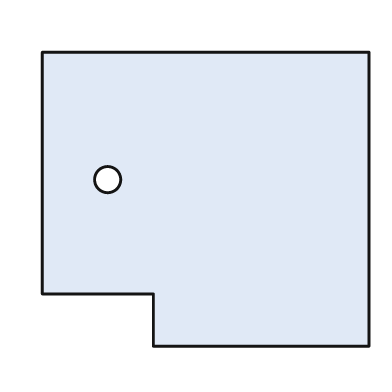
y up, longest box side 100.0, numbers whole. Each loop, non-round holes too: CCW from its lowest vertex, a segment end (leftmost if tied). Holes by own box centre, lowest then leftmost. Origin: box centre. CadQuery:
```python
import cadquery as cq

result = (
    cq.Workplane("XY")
    .moveTo(-16.0, -45.0)
    .lineTo(50.0, -45.0)
    .lineTo(50.0, 45.0)
    .lineTo(-50.0, 45.0)
    .lineTo(-50.0, -29.0)
    .lineTo(-16.0, -29.0)
    .close()
    .moveTo(-30.0, 6.0)
    .circle(4.0)
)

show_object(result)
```